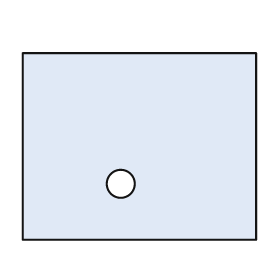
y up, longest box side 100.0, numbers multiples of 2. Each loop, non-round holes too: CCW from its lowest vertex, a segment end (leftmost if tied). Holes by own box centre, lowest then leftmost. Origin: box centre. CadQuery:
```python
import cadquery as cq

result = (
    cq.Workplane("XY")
    .moveTo(-50.0, -40.0)
    .lineTo(50.0, -40.0)
    .lineTo(50.0, 40.0)
    .lineTo(-50.0, 40.0)
    .close()
    .moveTo(-8.0, -16.0)
    .circle(6.0)
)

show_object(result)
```